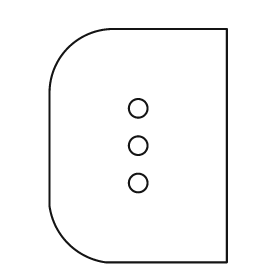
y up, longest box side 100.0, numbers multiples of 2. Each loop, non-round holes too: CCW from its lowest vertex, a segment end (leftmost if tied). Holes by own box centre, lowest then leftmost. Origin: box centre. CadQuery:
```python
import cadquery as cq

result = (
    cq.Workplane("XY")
    .moveTo(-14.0, -50.0)
    .lineTo(38.0, -50.0)
    .lineTo(38.0, 50.0)
    .lineTo(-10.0, 50.0)
    .threePointArc((-30.0, 42.0), (-38.0, 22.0))
    .lineTo(-38.0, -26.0)
    .threePointArc((-30.0, -42.0), (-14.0, -50.0))
    .close()
    .moveTo(0.0, -16.0)
    .circle(4.0)
    .moveTo(0.0, 0.0)
    .circle(4.0)
    .moveTo(0.0, 16.0)
    .circle(4.0)
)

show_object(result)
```